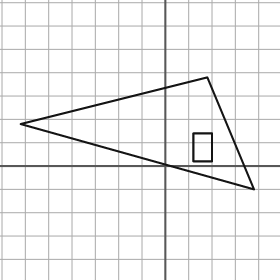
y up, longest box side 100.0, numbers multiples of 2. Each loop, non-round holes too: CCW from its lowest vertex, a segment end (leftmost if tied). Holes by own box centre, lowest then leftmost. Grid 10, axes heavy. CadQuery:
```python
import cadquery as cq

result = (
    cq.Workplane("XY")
    .moveTo(38.0, -10.0)
    .lineTo(18.0, 38.0)
    .lineTo(-62.0, 18.0)
    .close()
    .moveTo(12.0, 2.0)
    .lineTo(20.0, 2.0)
    .lineTo(20.0, 14.0)
    .lineTo(12.0, 14.0)
    .close()
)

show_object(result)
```